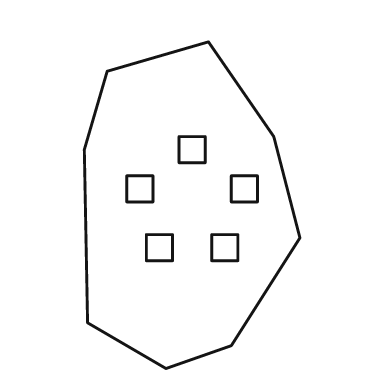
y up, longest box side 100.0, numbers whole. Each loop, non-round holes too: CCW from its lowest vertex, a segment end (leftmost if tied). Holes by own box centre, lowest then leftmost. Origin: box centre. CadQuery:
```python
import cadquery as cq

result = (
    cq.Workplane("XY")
    .moveTo(-8.0, -50.0)
    .lineTo(12.0, -43.0)
    .lineTo(33.0, -10.0)
    .lineTo(25.0, 21.0)
    .lineTo(5.0, 50.0)
    .lineTo(-26.0, 41.0)
    .lineTo(-33.0, 17.0)
    .lineTo(-32.0, -36.0)
    .close()
    .moveTo(-14.0, -17.0)
    .lineTo(-6.0, -17.0)
    .lineTo(-6.0, -9.0)
    .lineTo(-14.0, -9.0)
    .close()
    .moveTo(6.0, -17.0)
    .lineTo(14.0, -17.0)
    .lineTo(14.0, -9.0)
    .lineTo(6.0, -9.0)
    .close()
    .moveTo(-20.0, 1.0)
    .lineTo(-12.0, 1.0)
    .lineTo(-12.0, 9.0)
    .lineTo(-20.0, 9.0)
    .close()
    .moveTo(12.0, 1.0)
    .lineTo(20.0, 1.0)
    .lineTo(20.0, 9.0)
    .lineTo(12.0, 9.0)
    .close()
    .moveTo(-4.0, 13.0)
    .lineTo(4.0, 13.0)
    .lineTo(4.0, 21.0)
    .lineTo(-4.0, 21.0)
    .close()
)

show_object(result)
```